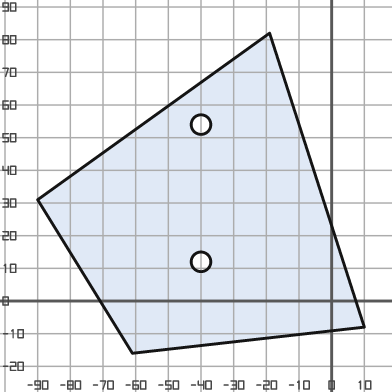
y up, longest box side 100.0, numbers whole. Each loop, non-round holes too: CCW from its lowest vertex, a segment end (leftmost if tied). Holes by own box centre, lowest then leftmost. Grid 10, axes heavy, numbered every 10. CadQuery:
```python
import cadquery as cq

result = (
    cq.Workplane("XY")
    .moveTo(-61.0, -16.0)
    .lineTo(10.0, -8.0)
    .lineTo(-19.0, 82.0)
    .lineTo(-90.0, 31.0)
    .close()
    .moveTo(-40.0, 12.0)
    .circle(3.0)
    .moveTo(-40.0, 54.0)
    .circle(3.0)
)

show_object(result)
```